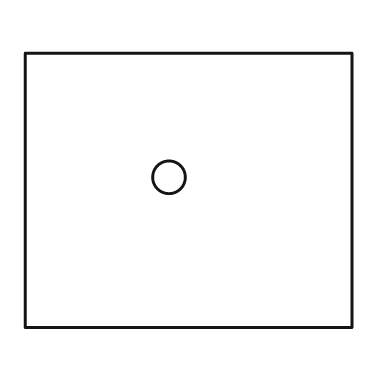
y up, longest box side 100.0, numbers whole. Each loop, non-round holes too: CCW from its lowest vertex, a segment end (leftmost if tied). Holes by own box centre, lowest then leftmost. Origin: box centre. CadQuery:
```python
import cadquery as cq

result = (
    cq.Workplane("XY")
    .moveTo(-50.0, -42.0)
    .lineTo(50.0, -42.0)
    .lineTo(50.0, 42.0)
    .lineTo(-50.0, 42.0)
    .close()
    .moveTo(-6.0, 4.0)
    .circle(5.0)
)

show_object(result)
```